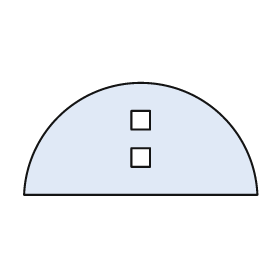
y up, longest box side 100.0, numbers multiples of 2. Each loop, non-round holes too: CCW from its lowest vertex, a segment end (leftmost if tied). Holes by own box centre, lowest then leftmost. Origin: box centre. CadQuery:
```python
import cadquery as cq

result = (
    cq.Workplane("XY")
    .moveTo(-50.0, -24.0)
    .lineTo(50.0, -24.0)
    .threePointArc((0.0, 24.0), (-50.0, -24.0))
    .close()
    .moveTo(-4.0, -12.0)
    .lineTo(4.0, -12.0)
    .lineTo(4.0, -4.0)
    .lineTo(-4.0, -4.0)
    .close()
    .moveTo(-4.0, 4.0)
    .lineTo(4.0, 4.0)
    .lineTo(4.0, 12.0)
    .lineTo(-4.0, 12.0)
    .close()
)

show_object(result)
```